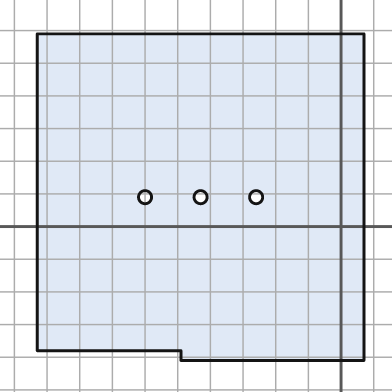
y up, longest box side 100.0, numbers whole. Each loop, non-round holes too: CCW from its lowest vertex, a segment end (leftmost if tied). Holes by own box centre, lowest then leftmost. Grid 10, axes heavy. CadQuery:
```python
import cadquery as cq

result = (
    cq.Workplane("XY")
    .moveTo(-49.0, -41.0)
    .lineTo(7.0, -41.0)
    .lineTo(7.0, 59.0)
    .lineTo(-93.0, 59.0)
    .lineTo(-93.0, -38.0)
    .lineTo(-49.0, -38.0)
    .close()
    .moveTo(-60.0, 9.0)
    .circle(2.0)
    .moveTo(-43.0, 9.0)
    .circle(2.0)
    .moveTo(-26.0, 9.0)
    .circle(2.0)
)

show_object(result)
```